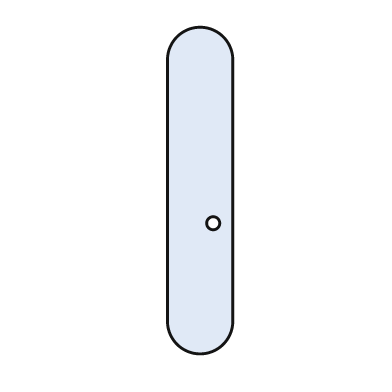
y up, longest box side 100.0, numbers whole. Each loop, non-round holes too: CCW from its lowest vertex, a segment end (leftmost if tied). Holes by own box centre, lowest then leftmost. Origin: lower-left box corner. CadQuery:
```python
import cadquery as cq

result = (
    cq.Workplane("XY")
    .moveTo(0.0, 10.0)
    .threePointArc((10.0, 0.0), (20.0, 10.0))
    .lineTo(20.0, 90.0)
    .threePointArc((10.0, 100.0), (0.0, 90.0))
    .close()
    .moveTo(14.0, 40.0)
    .circle(2.0)
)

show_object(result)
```